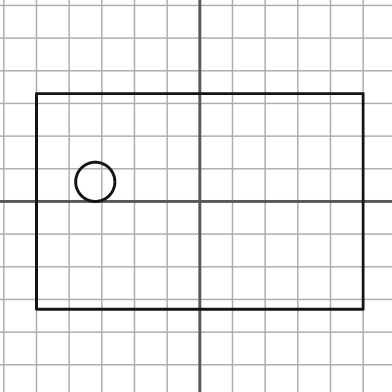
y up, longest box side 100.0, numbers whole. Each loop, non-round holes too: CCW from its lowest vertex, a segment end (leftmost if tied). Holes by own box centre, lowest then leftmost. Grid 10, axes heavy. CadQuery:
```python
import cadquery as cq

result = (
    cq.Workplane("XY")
    .moveTo(-50.0, -33.0)
    .lineTo(50.0, -33.0)
    .lineTo(50.0, 33.0)
    .lineTo(-50.0, 33.0)
    .close()
    .moveTo(-32.0, 6.0)
    .circle(6.0)
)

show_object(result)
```